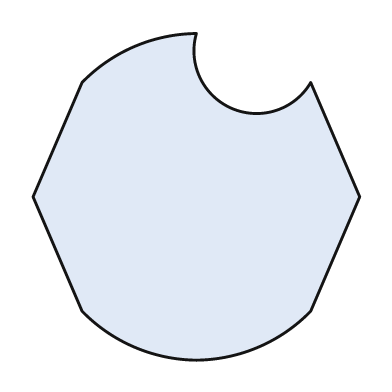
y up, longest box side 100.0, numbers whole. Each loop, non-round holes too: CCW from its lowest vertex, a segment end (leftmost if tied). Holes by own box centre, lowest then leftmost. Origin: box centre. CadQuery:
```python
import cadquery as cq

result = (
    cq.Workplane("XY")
    .moveTo(0.0, -50.0)
    .threePointArc((19.0, -46.0), (35.0, -35.0))
    .lineTo(50.0, 0.0)
    .lineTo(35.0, 35.0)
    .threePointArc((11.0, 27.0), (0.0, 50.0))
    .threePointArc((-19.0, 46.0), (-35.0, 35.0))
    .lineTo(-50.0, 0.0)
    .lineTo(-35.0, -35.0)
    .threePointArc((-19.0, -46.0), (0.0, -50.0))
    .close()
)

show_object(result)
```